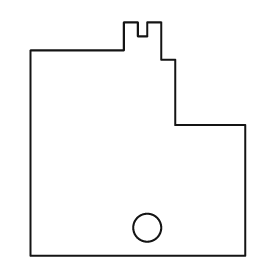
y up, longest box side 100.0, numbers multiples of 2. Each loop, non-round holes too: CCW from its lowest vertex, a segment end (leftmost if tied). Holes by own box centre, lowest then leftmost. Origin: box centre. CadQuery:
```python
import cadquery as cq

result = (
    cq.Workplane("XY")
    .moveTo(-46.0, -50.0)
    .lineTo(46.0, -50.0)
    .lineTo(46.0, 6.0)
    .lineTo(16.0, 6.0)
    .lineTo(16.0, 34.0)
    .lineTo(10.0, 34.0)
    .lineTo(10.0, 50.0)
    .lineTo(4.0, 50.0)
    .lineTo(4.0, 44.0)
    .lineTo(0.0, 44.0)
    .lineTo(0.0, 50.0)
    .lineTo(-6.0, 50.0)
    .lineTo(-6.0, 38.0)
    .lineTo(-46.0, 38.0)
    .close()
    .moveTo(4.0, -38.0)
    .circle(6.0)
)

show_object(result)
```